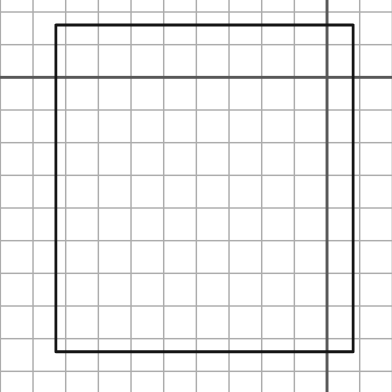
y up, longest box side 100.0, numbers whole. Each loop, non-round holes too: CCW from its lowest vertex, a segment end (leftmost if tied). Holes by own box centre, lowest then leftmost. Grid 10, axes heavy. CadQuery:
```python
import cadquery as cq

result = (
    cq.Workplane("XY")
    .moveTo(-83.0, -84.0)
    .lineTo(8.0, -84.0)
    .lineTo(8.0, 16.0)
    .lineTo(-83.0, 16.0)
    .close()
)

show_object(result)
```